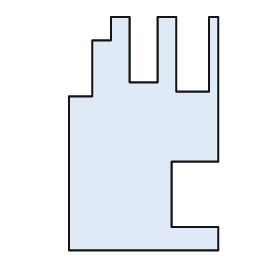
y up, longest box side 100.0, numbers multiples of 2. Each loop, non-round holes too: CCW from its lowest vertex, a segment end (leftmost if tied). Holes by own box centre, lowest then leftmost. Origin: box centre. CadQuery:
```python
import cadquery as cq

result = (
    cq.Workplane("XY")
    .moveTo(-32.0, -50.0)
    .lineTo(32.0, -50.0)
    .lineTo(32.0, -40.0)
    .lineTo(12.0, -40.0)
    .lineTo(12.0, -12.0)
    .lineTo(32.0, -12.0)
    .lineTo(32.0, 50.0)
    .lineTo(28.0, 50.0)
    .lineTo(28.0, 18.0)
    .lineTo(14.0, 18.0)
    .lineTo(14.0, 50.0)
    .lineTo(6.0, 50.0)
    .lineTo(6.0, 22.0)
    .lineTo(-6.0, 22.0)
    .lineTo(-6.0, 50.0)
    .lineTo(-14.0, 50.0)
    .lineTo(-14.0, 40.0)
    .lineTo(-22.0, 40.0)
    .lineTo(-22.0, 16.0)
    .lineTo(-32.0, 16.0)
    .close()
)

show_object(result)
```